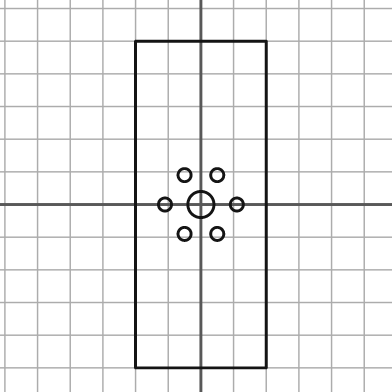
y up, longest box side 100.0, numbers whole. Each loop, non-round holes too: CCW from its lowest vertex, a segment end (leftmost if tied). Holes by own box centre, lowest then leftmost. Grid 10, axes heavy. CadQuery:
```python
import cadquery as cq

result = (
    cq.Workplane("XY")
    .moveTo(-20.0, -50.0)
    .lineTo(20.0, -50.0)
    .lineTo(20.0, 50.0)
    .lineTo(-20.0, 50.0)
    .close()
    .moveTo(-5.0, -9.0)
    .circle(2.0)
    .moveTo(5.0, -9.0)
    .circle(2.0)
    .moveTo(-11.0, 0.0)
    .circle(2.0)
    .moveTo(0.0, 0.0)
    .circle(4.0)
    .moveTo(11.0, 0.0)
    .circle(2.0)
    .moveTo(-5.0, 9.0)
    .circle(2.0)
    .moveTo(5.0, 9.0)
    .circle(2.0)
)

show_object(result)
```